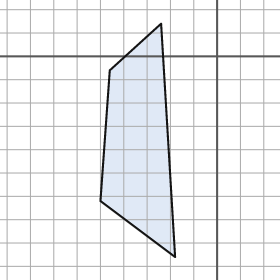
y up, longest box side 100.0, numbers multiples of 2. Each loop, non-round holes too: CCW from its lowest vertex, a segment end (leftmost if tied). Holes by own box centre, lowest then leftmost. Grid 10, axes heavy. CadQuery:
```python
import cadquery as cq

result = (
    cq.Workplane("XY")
    .moveTo(-18.0, -86.0)
    .lineTo(-24.0, 14.0)
    .lineTo(-46.0, -6.0)
    .lineTo(-50.0, -62.0)
    .close()
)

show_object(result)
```